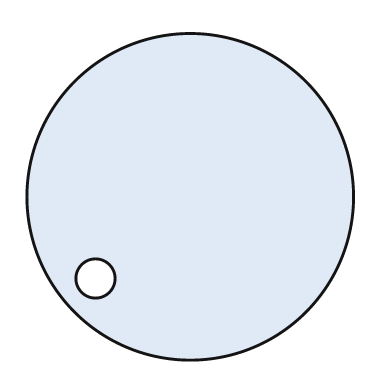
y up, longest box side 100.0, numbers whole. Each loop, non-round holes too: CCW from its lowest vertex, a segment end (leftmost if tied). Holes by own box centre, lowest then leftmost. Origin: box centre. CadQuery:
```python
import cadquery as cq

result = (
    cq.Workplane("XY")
    .moveTo(0.0, 0.0)
    .circle(50.0)
    .moveTo(-29.0, -25.0)
    .circle(6.0)
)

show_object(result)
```